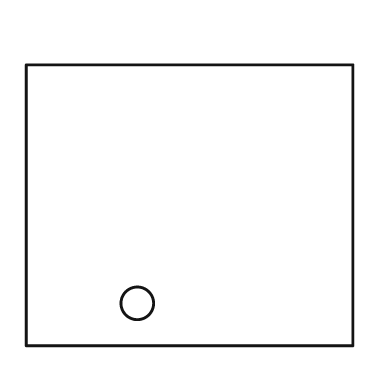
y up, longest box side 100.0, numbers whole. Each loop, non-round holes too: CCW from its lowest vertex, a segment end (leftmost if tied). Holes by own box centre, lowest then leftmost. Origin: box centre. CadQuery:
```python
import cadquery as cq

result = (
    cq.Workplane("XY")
    .moveTo(-50.0, -43.0)
    .lineTo(50.0, -43.0)
    .lineTo(50.0, 43.0)
    .lineTo(-50.0, 43.0)
    .close()
    .moveTo(-16.0, -30.0)
    .circle(5.0)
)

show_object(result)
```